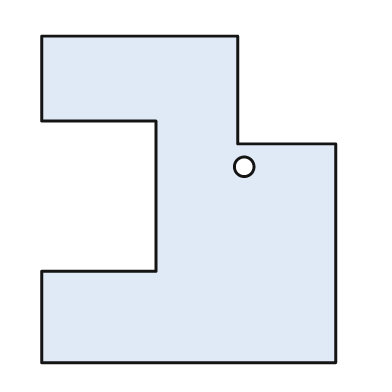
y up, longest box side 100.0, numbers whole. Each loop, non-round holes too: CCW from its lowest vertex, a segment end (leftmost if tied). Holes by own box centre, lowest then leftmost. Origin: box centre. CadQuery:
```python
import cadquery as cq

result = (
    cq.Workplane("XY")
    .moveTo(-45.0, -50.0)
    .lineTo(45.0, -50.0)
    .lineTo(45.0, 17.0)
    .lineTo(15.0, 17.0)
    .lineTo(15.0, 50.0)
    .lineTo(-45.0, 50.0)
    .lineTo(-45.0, 24.0)
    .lineTo(-10.0, 24.0)
    .lineTo(-10.0, -22.0)
    .lineTo(-45.0, -22.0)
    .close()
    .moveTo(17.0, 10.0)
    .circle(3.0)
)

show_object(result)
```